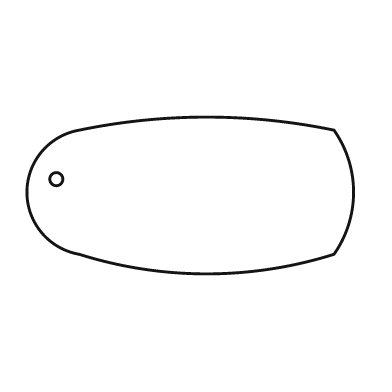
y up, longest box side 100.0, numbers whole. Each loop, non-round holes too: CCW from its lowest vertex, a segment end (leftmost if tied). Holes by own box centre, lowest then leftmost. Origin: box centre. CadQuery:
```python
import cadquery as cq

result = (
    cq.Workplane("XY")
    .moveTo(-34.0, -18.0)
    .threePointArc((5.0, -24.0), (44.0, -18.0))
    .threePointArc((50.0, 1.0), (44.0, 20.0))
    .threePointArc((5.0, 24.0), (-34.0, 20.0))
    .threePointArc((-50.0, 1.0), (-34.0, -18.0))
    .close()
    .moveTo(-41.0, 5.0)
    .circle(2.0)
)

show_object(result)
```